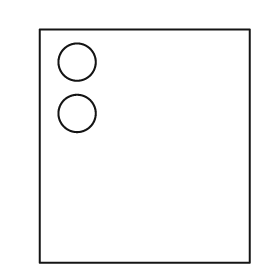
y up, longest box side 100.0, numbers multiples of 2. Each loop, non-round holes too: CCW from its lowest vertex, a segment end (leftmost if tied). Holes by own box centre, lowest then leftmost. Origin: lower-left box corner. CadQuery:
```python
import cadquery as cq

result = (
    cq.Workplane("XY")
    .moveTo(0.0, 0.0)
    .lineTo(90.0, 0.0)
    .lineTo(90.0, 100.0)
    .lineTo(0.0, 100.0)
    .close()
    .moveTo(16.0, 64.0)
    .circle(8.0)
    .moveTo(16.0, 86.0)
    .circle(8.0)
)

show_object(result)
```